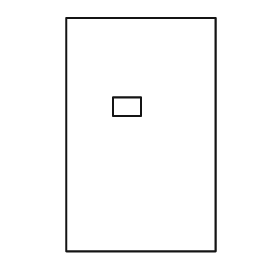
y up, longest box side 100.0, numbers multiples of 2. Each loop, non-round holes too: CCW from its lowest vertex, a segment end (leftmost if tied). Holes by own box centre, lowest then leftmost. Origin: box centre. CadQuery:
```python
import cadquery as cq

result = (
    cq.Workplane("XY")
    .moveTo(-32.0, -50.0)
    .lineTo(32.0, -50.0)
    .lineTo(32.0, 50.0)
    .lineTo(-32.0, 50.0)
    .close()
    .moveTo(-12.0, 8.0)
    .lineTo(0.0, 8.0)
    .lineTo(0.0, 16.0)
    .lineTo(-12.0, 16.0)
    .close()
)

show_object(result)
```